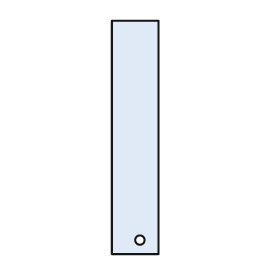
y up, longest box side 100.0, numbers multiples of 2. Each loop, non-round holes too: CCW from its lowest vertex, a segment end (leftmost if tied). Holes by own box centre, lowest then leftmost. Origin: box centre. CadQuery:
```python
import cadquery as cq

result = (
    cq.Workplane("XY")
    .moveTo(-10.0, -50.0)
    .lineTo(10.0, -50.0)
    .lineTo(10.0, 50.0)
    .lineTo(-10.0, 50.0)
    .close()
    .moveTo(2.0, -44.0)
    .circle(2.0)
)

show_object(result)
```